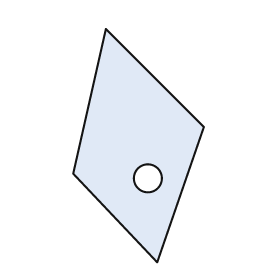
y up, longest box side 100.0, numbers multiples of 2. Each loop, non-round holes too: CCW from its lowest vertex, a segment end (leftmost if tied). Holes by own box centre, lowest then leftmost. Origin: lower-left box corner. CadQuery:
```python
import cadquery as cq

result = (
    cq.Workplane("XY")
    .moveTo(36.0, 0.0)
    .lineTo(56.0, 58.0)
    .lineTo(14.0, 100.0)
    .lineTo(0.0, 38.0)
    .close()
    .moveTo(32.0, 36.0)
    .circle(6.0)
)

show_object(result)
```